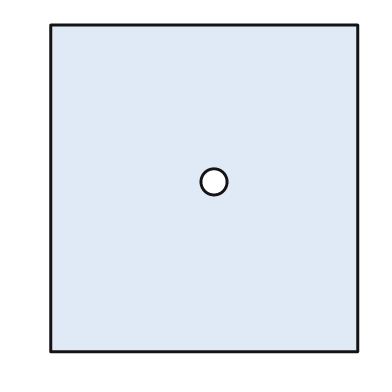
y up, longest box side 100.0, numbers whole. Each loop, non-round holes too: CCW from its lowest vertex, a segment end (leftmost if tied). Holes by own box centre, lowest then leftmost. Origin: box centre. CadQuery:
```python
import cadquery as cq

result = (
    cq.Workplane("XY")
    .moveTo(-47.0, -50.0)
    .lineTo(47.0, -50.0)
    .lineTo(47.0, 50.0)
    .lineTo(-47.0, 50.0)
    .close()
    .moveTo(3.0, 2.0)
    .circle(4.0)
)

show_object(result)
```